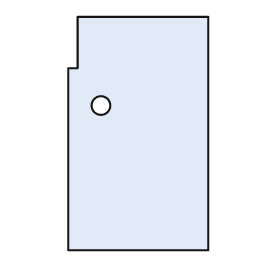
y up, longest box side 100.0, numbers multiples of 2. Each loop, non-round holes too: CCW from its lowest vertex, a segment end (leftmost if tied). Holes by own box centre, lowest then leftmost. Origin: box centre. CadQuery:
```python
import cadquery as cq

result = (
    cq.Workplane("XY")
    .moveTo(-30.0, -50.0)
    .lineTo(30.0, -50.0)
    .lineTo(30.0, 50.0)
    .lineTo(-26.0, 50.0)
    .lineTo(-26.0, 28.0)
    .lineTo(-30.0, 28.0)
    .close()
    .moveTo(-16.0, 12.0)
    .circle(4.0)
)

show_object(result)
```